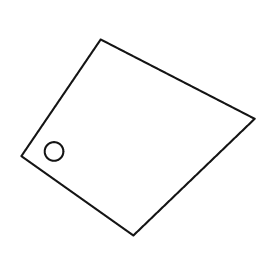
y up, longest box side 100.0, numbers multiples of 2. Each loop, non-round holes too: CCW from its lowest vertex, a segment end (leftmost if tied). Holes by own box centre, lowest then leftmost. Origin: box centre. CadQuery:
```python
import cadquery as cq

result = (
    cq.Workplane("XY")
    .moveTo(-2.0, -42.0)
    .lineTo(50.0, 8.0)
    .lineTo(-16.0, 42.0)
    .lineTo(-50.0, -8.0)
    .close()
    .moveTo(-36.0, -6.0)
    .circle(4.0)
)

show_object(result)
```